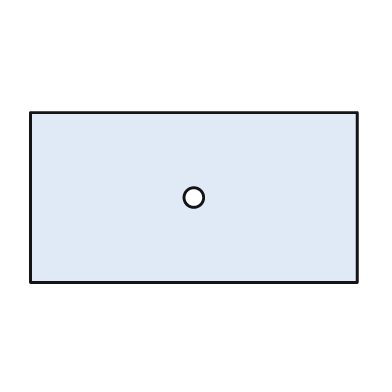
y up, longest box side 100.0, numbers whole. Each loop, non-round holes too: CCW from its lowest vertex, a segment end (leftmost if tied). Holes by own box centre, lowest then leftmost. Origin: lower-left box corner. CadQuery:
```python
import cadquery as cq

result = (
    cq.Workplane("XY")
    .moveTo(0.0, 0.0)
    .lineTo(100.0, 0.0)
    .lineTo(100.0, 52.0)
    .lineTo(0.0, 52.0)
    .close()
    .moveTo(50.0, 26.0)
    .circle(3.0)
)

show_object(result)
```